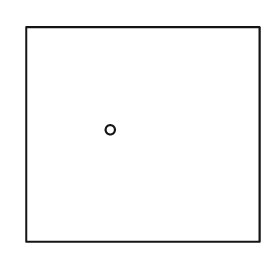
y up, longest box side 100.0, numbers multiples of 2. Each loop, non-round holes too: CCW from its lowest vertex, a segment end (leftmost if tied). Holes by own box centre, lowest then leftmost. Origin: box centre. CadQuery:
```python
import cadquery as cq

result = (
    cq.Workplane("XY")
    .moveTo(-50.0, -46.0)
    .lineTo(50.0, -46.0)
    .lineTo(50.0, 46.0)
    .lineTo(-50.0, 46.0)
    .close()
    .moveTo(-14.0, 2.0)
    .circle(2.0)
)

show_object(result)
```